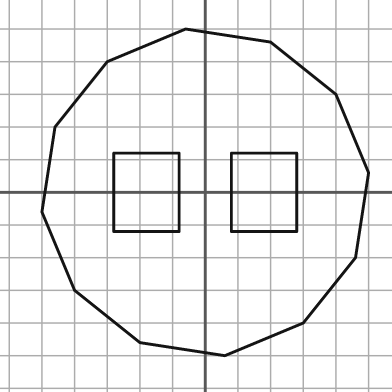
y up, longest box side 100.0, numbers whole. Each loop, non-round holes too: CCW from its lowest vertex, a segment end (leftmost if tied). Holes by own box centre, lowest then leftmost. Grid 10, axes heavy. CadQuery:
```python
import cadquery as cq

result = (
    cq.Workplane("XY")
    .moveTo(6.0, -50.0)
    .lineTo(30.0, -40.0)
    .lineTo(46.0, -20.0)
    .lineTo(50.0, 6.0)
    .lineTo(40.0, 30.0)
    .lineTo(20.0, 46.0)
    .lineTo(-6.0, 50.0)
    .lineTo(-30.0, 40.0)
    .lineTo(-46.0, 20.0)
    .lineTo(-50.0, -6.0)
    .lineTo(-40.0, -30.0)
    .lineTo(-20.0, -46.0)
    .close()
    .moveTo(-28.0, -12.0)
    .lineTo(-8.0, -12.0)
    .lineTo(-8.0, 12.0)
    .lineTo(-28.0, 12.0)
    .close()
    .moveTo(8.0, -12.0)
    .lineTo(28.0, -12.0)
    .lineTo(28.0, 12.0)
    .lineTo(8.0, 12.0)
    .close()
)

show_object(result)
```